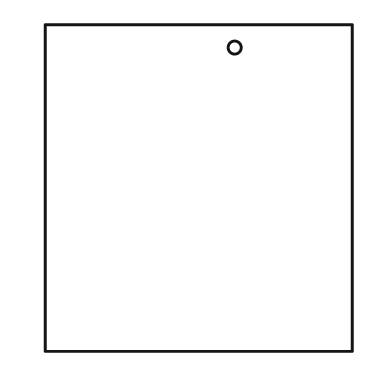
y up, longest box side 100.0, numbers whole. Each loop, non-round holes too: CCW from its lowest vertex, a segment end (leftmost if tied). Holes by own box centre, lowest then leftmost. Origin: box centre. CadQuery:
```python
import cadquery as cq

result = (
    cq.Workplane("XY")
    .moveTo(-47.0, -50.0)
    .lineTo(47.0, -50.0)
    .lineTo(47.0, 50.0)
    .lineTo(-47.0, 50.0)
    .close()
    .moveTo(11.0, 43.0)
    .circle(2.0)
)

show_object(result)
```